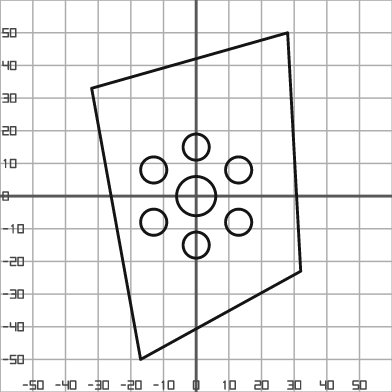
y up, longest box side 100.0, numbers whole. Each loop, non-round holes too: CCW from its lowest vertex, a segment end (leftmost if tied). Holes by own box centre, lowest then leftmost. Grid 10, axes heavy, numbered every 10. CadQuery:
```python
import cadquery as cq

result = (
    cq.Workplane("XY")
    .moveTo(-17.0, -50.0)
    .lineTo(32.0, -23.0)
    .lineTo(28.0, 50.0)
    .lineTo(-32.0, 33.0)
    .close()
    .moveTo(0.0, -15.0)
    .circle(4.0)
    .moveTo(-13.0, -8.0)
    .circle(4.0)
    .moveTo(13.0, -8.0)
    .circle(4.0)
    .moveTo(0.0, 0.0)
    .circle(6.0)
    .moveTo(-13.0, 8.0)
    .circle(4.0)
    .moveTo(13.0, 8.0)
    .circle(4.0)
    .moveTo(0.0, 15.0)
    .circle(4.0)
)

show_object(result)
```